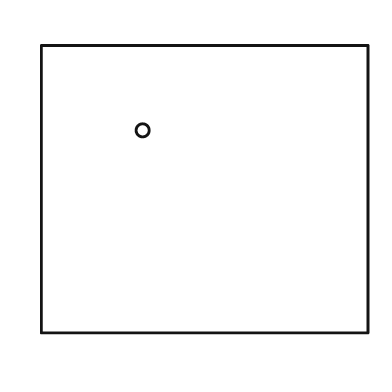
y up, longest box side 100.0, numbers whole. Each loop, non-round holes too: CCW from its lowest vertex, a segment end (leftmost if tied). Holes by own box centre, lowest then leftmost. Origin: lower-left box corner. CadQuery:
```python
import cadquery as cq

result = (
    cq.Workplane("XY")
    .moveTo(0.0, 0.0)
    .lineTo(100.0, 0.0)
    .lineTo(100.0, 88.0)
    .lineTo(0.0, 88.0)
    .close()
    .moveTo(31.0, 62.0)
    .circle(2.0)
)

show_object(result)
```